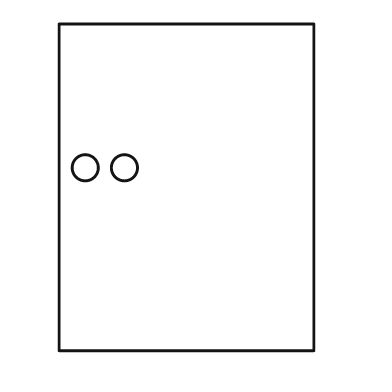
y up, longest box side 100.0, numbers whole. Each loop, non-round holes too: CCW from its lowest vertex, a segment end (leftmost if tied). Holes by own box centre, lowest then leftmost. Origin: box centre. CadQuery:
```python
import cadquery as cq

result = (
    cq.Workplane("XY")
    .moveTo(-39.0, -50.0)
    .lineTo(39.0, -50.0)
    .lineTo(39.0, 50.0)
    .lineTo(-39.0, 50.0)
    .close()
    .moveTo(-31.0, 6.0)
    .circle(4.0)
    .moveTo(-19.0, 6.0)
    .circle(4.0)
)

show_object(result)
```